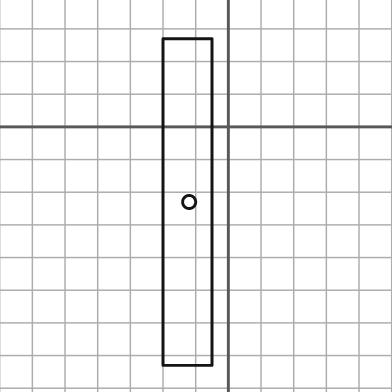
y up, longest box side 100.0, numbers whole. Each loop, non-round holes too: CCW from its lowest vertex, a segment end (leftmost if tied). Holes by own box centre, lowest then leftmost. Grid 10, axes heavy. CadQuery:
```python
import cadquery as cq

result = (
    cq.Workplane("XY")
    .moveTo(-20.0, -73.0)
    .lineTo(-5.0, -73.0)
    .lineTo(-5.0, 27.0)
    .lineTo(-20.0, 27.0)
    .close()
    .moveTo(-12.0, -23.0)
    .circle(2.0)
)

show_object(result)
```